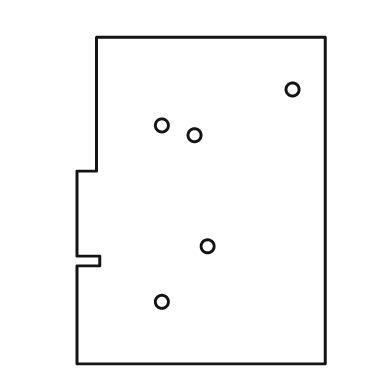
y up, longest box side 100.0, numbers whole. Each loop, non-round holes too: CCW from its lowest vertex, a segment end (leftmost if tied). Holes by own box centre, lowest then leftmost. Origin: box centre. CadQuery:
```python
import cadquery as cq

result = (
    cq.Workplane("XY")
    .moveTo(-38.0, -50.0)
    .lineTo(38.0, -50.0)
    .lineTo(38.0, 50.0)
    .lineTo(-32.0, 50.0)
    .lineTo(-32.0, 9.0)
    .lineTo(-38.0, 9.0)
    .lineTo(-38.0, -17.0)
    .lineTo(-31.0, -17.0)
    .lineTo(-31.0, -20.0)
    .lineTo(-38.0, -20.0)
    .close()
    .moveTo(-12.0, -31.0)
    .circle(2.0)
    .moveTo(2.0, -14.0)
    .circle(2.0)
    .moveTo(-2.0, 20.0)
    .circle(2.0)
    .moveTo(-12.0, 23.0)
    .circle(2.0)
    .moveTo(28.0, 34.0)
    .circle(2.0)
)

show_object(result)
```